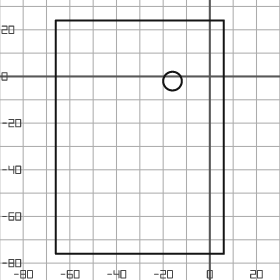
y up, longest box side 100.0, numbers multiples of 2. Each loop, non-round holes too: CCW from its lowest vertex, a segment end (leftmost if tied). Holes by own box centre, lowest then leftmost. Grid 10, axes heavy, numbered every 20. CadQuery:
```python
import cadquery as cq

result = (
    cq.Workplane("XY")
    .moveTo(-66.0, -76.0)
    .lineTo(6.0, -76.0)
    .lineTo(6.0, 24.0)
    .lineTo(-66.0, 24.0)
    .close()
    .moveTo(-16.0, -2.0)
    .circle(4.0)
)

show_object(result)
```